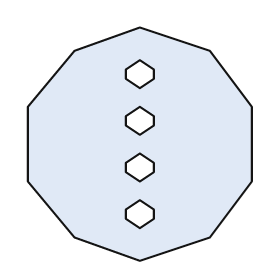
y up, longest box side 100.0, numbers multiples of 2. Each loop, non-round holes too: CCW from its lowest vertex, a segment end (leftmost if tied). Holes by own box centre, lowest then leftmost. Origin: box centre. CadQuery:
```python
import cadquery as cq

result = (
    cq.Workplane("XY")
    .moveTo(0.0, -50.0)
    .lineTo(30.0, -40.0)
    .lineTo(48.0, -16.0)
    .lineTo(48.0, 16.0)
    .lineTo(30.0, 40.0)
    .lineTo(0.0, 50.0)
    .lineTo(-28.0, 40.0)
    .lineTo(-48.0, 16.0)
    .lineTo(-48.0, -16.0)
    .lineTo(-28.0, -40.0)
    .close()
    .moveTo(0.0, -36.0)
    .lineTo(6.0, -32.0)
    .lineTo(6.0, -28.0)
    .lineTo(0.0, -24.0)
    .lineTo(-6.0, -28.0)
    .lineTo(-6.0, -32.0)
    .close()
    .moveTo(0.0, -16.0)
    .lineTo(6.0, -12.0)
    .lineTo(6.0, -8.0)
    .lineTo(0.0, -4.0)
    .lineTo(-6.0, -8.0)
    .lineTo(-6.0, -12.0)
    .close()
    .moveTo(0.0, 4.0)
    .lineTo(6.0, 8.0)
    .lineTo(6.0, 12.0)
    .lineTo(0.0, 16.0)
    .lineTo(-6.0, 12.0)
    .lineTo(-6.0, 8.0)
    .close()
    .moveTo(0.0, 24.0)
    .lineTo(6.0, 28.0)
    .lineTo(6.0, 32.0)
    .lineTo(0.0, 36.0)
    .lineTo(-6.0, 32.0)
    .lineTo(-6.0, 28.0)
    .close()
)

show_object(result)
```